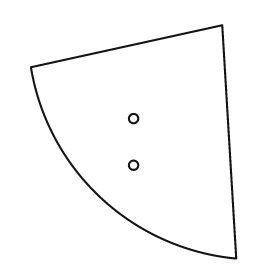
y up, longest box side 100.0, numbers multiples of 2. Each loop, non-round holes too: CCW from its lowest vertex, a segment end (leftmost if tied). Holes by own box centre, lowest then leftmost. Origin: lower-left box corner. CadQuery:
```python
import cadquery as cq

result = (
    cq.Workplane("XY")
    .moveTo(88.0, 0.0)
    .lineTo(82.0, 100.0)
    .lineTo(0.0, 82.0)
    .threePointArc((30.0, 26.0), (88.0, 0.0))
    .close()
    .moveTo(44.0, 40.0)
    .circle(2.0)
    .moveTo(44.0, 60.0)
    .circle(2.0)
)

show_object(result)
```